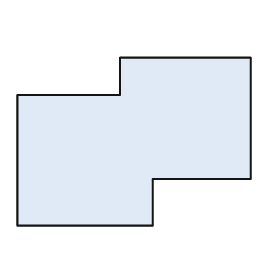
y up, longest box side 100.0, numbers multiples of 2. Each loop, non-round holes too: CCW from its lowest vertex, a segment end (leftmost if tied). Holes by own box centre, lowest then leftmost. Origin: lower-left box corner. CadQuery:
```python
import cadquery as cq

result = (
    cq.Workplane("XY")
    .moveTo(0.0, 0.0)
    .lineTo(58.0, 0.0)
    .lineTo(58.0, 20.0)
    .lineTo(100.0, 20.0)
    .lineTo(100.0, 72.0)
    .lineTo(44.0, 72.0)
    .lineTo(44.0, 56.0)
    .lineTo(0.0, 56.0)
    .close()
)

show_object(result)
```